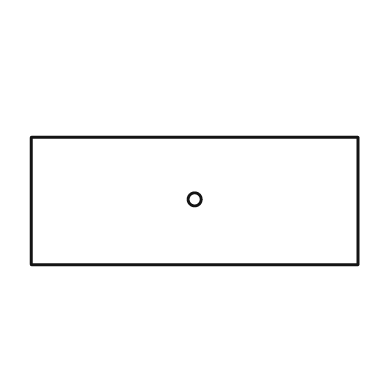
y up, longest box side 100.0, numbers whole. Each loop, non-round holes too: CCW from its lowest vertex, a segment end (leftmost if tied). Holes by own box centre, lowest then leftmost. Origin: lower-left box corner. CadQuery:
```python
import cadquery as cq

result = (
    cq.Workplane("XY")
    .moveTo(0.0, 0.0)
    .lineTo(100.0, 0.0)
    .lineTo(100.0, 39.0)
    .lineTo(0.0, 39.0)
    .close()
    .moveTo(50.0, 20.0)
    .circle(2.0)
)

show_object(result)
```